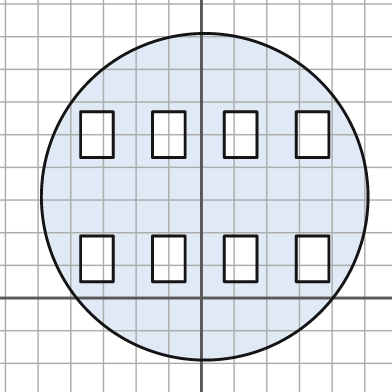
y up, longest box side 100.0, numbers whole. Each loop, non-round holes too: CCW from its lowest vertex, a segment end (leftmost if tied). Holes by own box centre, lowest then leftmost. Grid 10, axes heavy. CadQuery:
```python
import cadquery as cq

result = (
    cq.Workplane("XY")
    .moveTo(1.0, 31.0)
    .circle(50.0)
    .moveTo(-37.0, 5.0)
    .lineTo(-27.0, 5.0)
    .lineTo(-27.0, 19.0)
    .lineTo(-37.0, 19.0)
    .close()
    .moveTo(-15.0, 5.0)
    .lineTo(-5.0, 5.0)
    .lineTo(-5.0, 19.0)
    .lineTo(-15.0, 19.0)
    .close()
    .moveTo(7.0, 5.0)
    .lineTo(17.0, 5.0)
    .lineTo(17.0, 19.0)
    .lineTo(7.0, 19.0)
    .close()
    .moveTo(29.0, 5.0)
    .lineTo(39.0, 5.0)
    .lineTo(39.0, 19.0)
    .lineTo(29.0, 19.0)
    .close()
    .moveTo(-37.0, 43.0)
    .lineTo(-27.0, 43.0)
    .lineTo(-27.0, 57.0)
    .lineTo(-37.0, 57.0)
    .close()
    .moveTo(-15.0, 43.0)
    .lineTo(-5.0, 43.0)
    .lineTo(-5.0, 57.0)
    .lineTo(-15.0, 57.0)
    .close()
    .moveTo(7.0, 43.0)
    .lineTo(17.0, 43.0)
    .lineTo(17.0, 57.0)
    .lineTo(7.0, 57.0)
    .close()
    .moveTo(29.0, 43.0)
    .lineTo(39.0, 43.0)
    .lineTo(39.0, 57.0)
    .lineTo(29.0, 57.0)
    .close()
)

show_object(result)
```